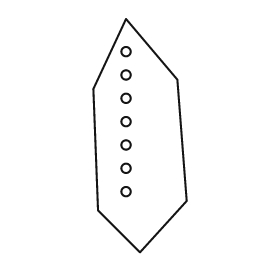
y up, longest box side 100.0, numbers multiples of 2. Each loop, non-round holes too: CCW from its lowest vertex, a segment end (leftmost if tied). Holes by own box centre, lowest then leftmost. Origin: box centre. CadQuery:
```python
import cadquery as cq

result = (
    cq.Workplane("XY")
    .moveTo(0.0, -50.0)
    .lineTo(20.0, -28.0)
    .lineTo(16.0, 24.0)
    .lineTo(-6.0, 50.0)
    .lineTo(-20.0, 20.0)
    .lineTo(-18.0, -32.0)
    .close()
    .moveTo(-6.0, -24.0)
    .circle(2.0)
    .moveTo(-6.0, -14.0)
    .circle(2.0)
    .moveTo(-6.0, -4.0)
    .circle(2.0)
    .moveTo(-6.0, 6.0)
    .circle(2.0)
    .moveTo(-6.0, 16.0)
    .circle(2.0)
    .moveTo(-6.0, 26.0)
    .circle(2.0)
    .moveTo(-6.0, 36.0)
    .circle(2.0)
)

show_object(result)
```